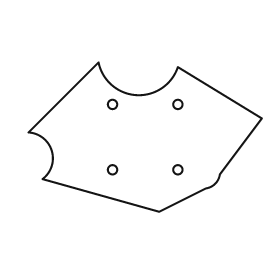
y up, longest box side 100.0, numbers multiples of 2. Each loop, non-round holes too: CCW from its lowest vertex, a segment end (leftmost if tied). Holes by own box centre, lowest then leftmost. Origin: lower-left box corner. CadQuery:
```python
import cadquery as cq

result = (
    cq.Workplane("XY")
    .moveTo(56.0, 0.0)
    .lineTo(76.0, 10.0)
    .threePointArc((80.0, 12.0), (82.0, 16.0))
    .lineTo(100.0, 40.0)
    .lineTo(64.0, 62.0)
    .threePointArc((46.0, 50.0), (30.0, 64.0))
    .lineTo(0.0, 34.0)
    .threePointArc((10.0, 26.0), (6.0, 14.0))
    .close()
    .moveTo(36.0, 18.0)
    .circle(2.0)
    .moveTo(64.0, 18.0)
    .circle(2.0)
    .moveTo(36.0, 46.0)
    .circle(2.0)
    .moveTo(64.0, 46.0)
    .circle(2.0)
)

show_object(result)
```